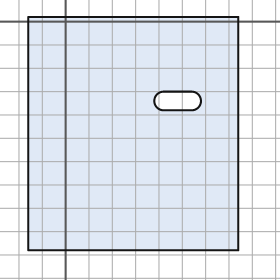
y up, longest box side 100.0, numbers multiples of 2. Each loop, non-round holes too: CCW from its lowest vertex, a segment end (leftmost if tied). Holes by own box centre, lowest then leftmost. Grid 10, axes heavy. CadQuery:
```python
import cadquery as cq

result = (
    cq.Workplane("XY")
    .moveTo(-16.0, -98.0)
    .lineTo(74.0, -98.0)
    .lineTo(74.0, 2.0)
    .lineTo(-16.0, 2.0)
    .close()
    .moveTo(42.0, -38.0)
    .lineTo(54.0, -38.0)
    .threePointArc((58.0, -34.0), (54.0, -30.0))
    .lineTo(42.0, -30.0)
    .threePointArc((38.0, -34.0), (42.0, -38.0))
    .close()
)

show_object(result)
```